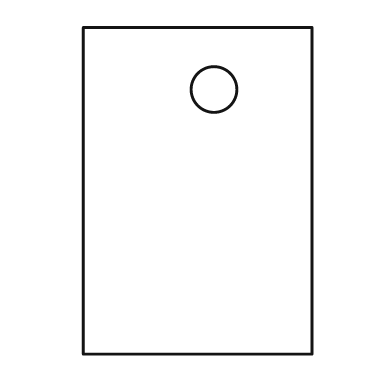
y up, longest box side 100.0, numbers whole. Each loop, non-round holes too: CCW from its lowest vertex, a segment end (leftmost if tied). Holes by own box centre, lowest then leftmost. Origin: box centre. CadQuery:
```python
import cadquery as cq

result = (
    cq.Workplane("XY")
    .moveTo(-35.0, -50.0)
    .lineTo(35.0, -50.0)
    .lineTo(35.0, 50.0)
    .lineTo(-35.0, 50.0)
    .close()
    .moveTo(5.0, 31.0)
    .circle(7.0)
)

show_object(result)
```